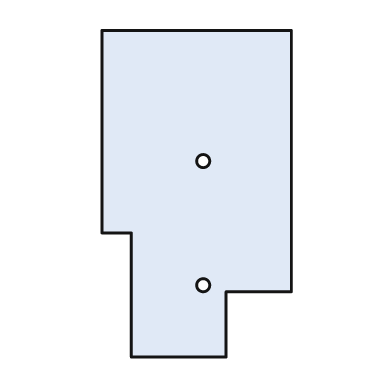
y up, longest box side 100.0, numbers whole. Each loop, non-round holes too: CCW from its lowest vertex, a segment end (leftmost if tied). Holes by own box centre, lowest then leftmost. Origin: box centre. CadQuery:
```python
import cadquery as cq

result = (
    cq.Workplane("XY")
    .moveTo(-20.0, -50.0)
    .lineTo(9.0, -50.0)
    .lineTo(9.0, -30.0)
    .lineTo(29.0, -30.0)
    .lineTo(29.0, 50.0)
    .lineTo(-29.0, 50.0)
    .lineTo(-29.0, -12.0)
    .lineTo(-20.0, -12.0)
    .close()
    .moveTo(2.0, -28.0)
    .circle(2.0)
    .moveTo(2.0, 10.0)
    .circle(2.0)
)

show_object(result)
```